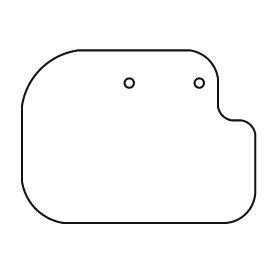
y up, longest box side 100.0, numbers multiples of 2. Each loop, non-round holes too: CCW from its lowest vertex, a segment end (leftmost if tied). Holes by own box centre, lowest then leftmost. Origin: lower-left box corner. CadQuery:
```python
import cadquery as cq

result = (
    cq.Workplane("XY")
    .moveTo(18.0, 0.0)
    .lineTo(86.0, 0.0)
    .threePointArc((96.0, 4.0), (100.0, 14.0))
    .lineTo(100.0, 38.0)
    .threePointArc((98.0, 42.0), (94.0, 44.0))
    .lineTo(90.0, 44.0)
    .threePointArc((86.0, 46.0), (84.0, 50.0))
    .lineTo(84.0, 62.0)
    .threePointArc((80.0, 70.0), (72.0, 74.0))
    .lineTo(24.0, 74.0)
    .threePointArc((8.0, 66.0), (0.0, 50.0))
    .lineTo(0.0, 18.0)
    .threePointArc((6.0, 6.0), (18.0, 0.0))
    .close()
    .moveTo(46.0, 60.0)
    .circle(2.0)
    .moveTo(76.0, 60.0)
    .circle(2.0)
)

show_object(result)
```